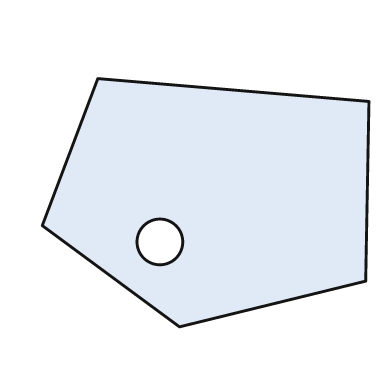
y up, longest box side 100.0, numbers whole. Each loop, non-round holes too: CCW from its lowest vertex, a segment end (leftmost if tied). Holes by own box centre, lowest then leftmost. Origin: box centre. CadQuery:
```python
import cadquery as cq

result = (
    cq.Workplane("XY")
    .moveTo(-8.0, -38.0)
    .lineTo(49.0, -24.0)
    .lineTo(50.0, 31.0)
    .lineTo(-33.0, 38.0)
    .lineTo(-50.0, -7.0)
    .close()
    .moveTo(-14.0, -12.0)
    .circle(7.0)
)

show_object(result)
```